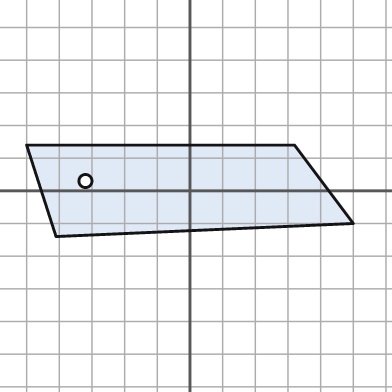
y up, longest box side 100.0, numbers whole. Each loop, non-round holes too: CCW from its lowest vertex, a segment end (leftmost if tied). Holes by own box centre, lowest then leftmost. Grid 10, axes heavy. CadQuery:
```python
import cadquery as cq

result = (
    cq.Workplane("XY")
    .moveTo(-41.0, -14.0)
    .lineTo(50.0, -10.0)
    .lineTo(32.0, 14.0)
    .lineTo(-50.0, 14.0)
    .close()
    .moveTo(-32.0, 3.0)
    .circle(2.0)
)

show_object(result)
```